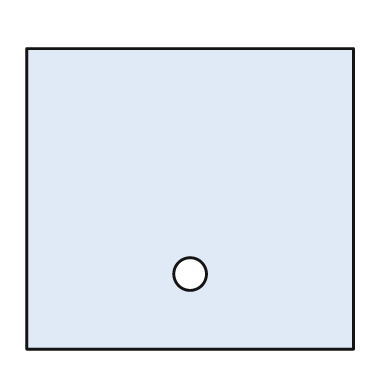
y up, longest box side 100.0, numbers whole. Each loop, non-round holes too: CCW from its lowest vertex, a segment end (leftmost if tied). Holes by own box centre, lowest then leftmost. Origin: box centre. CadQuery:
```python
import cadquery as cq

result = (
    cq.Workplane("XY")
    .moveTo(-50.0, -46.0)
    .lineTo(50.0, -46.0)
    .lineTo(50.0, 46.0)
    .lineTo(-50.0, 46.0)
    .close()
    .moveTo(0.0, -23.0)
    .circle(5.0)
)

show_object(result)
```